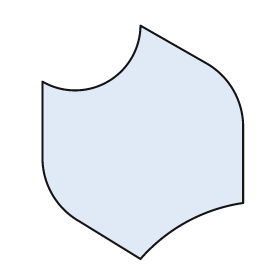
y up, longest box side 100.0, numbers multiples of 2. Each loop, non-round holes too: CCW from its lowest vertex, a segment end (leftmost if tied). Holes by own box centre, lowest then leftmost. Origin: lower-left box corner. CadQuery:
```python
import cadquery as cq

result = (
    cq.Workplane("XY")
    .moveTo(42.0, 0.0)
    .threePointArc((62.0, 16.0), (86.0, 24.0))
    .lineTo(86.0, 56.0)
    .threePointArc((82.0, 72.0), (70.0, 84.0))
    .lineTo(42.0, 100.0)
    .threePointArc((28.0, 76.0), (0.0, 76.0))
    .lineTo(0.0, 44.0)
    .threePointArc((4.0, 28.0), (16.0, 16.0))
    .close()
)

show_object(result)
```